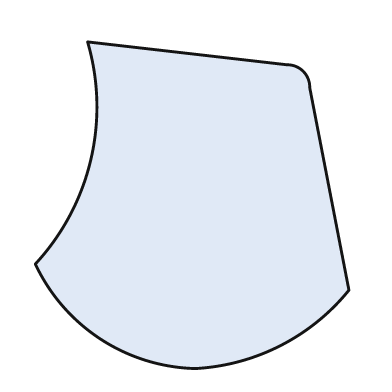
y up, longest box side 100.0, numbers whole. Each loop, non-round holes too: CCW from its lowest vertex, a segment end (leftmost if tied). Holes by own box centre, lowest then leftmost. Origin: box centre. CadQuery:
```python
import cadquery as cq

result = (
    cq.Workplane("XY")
    .moveTo(1.0, -50.0)
    .threePointArc((27.0, -43.0), (48.0, -26.0))
    .lineTo(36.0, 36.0)
    .threePointArc((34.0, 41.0), (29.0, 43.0))
    .lineTo(-32.0, 50.0)
    .threePointArc((-31.0, 14.0), (-48.0, -18.0))
    .threePointArc((-28.0, -41.0), (1.0, -50.0))
    .close()
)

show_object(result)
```